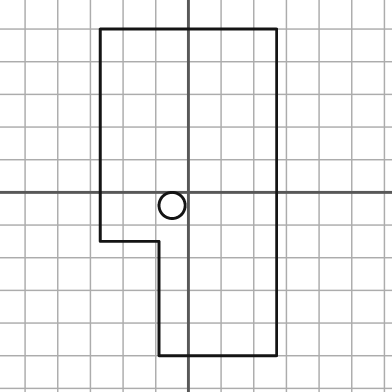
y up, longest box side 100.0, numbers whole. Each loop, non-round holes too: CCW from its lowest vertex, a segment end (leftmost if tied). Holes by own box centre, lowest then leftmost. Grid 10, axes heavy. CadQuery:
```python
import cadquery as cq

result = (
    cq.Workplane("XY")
    .moveTo(-9.0, -50.0)
    .lineTo(27.0, -50.0)
    .lineTo(27.0, 50.0)
    .lineTo(-27.0, 50.0)
    .lineTo(-27.0, -15.0)
    .lineTo(-9.0, -15.0)
    .close()
    .moveTo(-5.0, -4.0)
    .circle(4.0)
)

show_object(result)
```